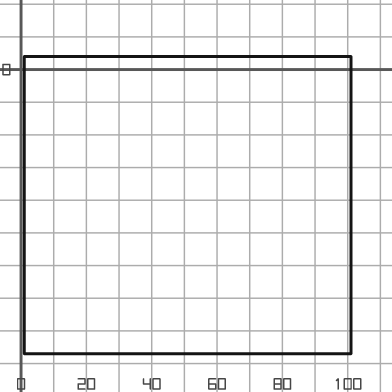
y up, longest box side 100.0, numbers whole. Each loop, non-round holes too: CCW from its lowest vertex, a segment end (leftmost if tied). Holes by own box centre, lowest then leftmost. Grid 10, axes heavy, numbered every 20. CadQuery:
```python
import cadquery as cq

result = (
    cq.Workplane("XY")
    .moveTo(1.0, -87.0)
    .lineTo(101.0, -87.0)
    .lineTo(101.0, 4.0)
    .lineTo(1.0, 4.0)
    .close()
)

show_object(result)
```